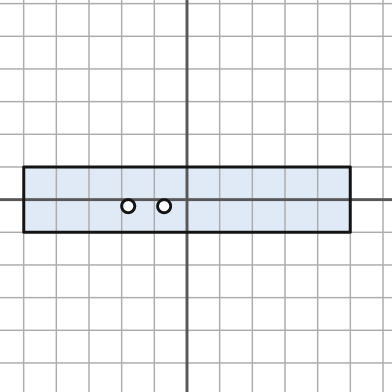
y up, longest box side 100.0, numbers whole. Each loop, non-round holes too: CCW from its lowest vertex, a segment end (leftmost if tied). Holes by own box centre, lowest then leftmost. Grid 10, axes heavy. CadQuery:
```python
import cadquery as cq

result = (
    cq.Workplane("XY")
    .moveTo(-50.0, -10.0)
    .lineTo(50.0, -10.0)
    .lineTo(50.0, 10.0)
    .lineTo(-50.0, 10.0)
    .close()
    .moveTo(-18.0, -2.0)
    .circle(2.0)
    .moveTo(-7.0, -2.0)
    .circle(2.0)
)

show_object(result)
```